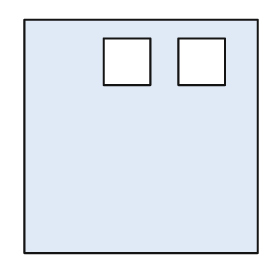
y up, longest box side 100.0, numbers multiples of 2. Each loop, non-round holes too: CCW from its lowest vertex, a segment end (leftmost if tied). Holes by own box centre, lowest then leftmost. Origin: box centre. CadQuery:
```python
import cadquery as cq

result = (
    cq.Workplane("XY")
    .moveTo(-50.0, -50.0)
    .lineTo(50.0, -50.0)
    .lineTo(50.0, 50.0)
    .lineTo(-50.0, 50.0)
    .close()
    .moveTo(-16.0, 22.0)
    .lineTo(4.0, 22.0)
    .lineTo(4.0, 42.0)
    .lineTo(-16.0, 42.0)
    .close()
    .moveTo(16.0, 22.0)
    .lineTo(36.0, 22.0)
    .lineTo(36.0, 42.0)
    .lineTo(16.0, 42.0)
    .close()
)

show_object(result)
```